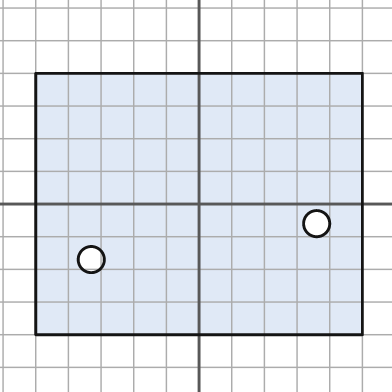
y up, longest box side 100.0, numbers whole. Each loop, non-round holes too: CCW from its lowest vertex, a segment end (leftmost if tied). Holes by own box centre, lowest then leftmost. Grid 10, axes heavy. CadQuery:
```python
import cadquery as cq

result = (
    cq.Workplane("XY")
    .moveTo(-50.0, -40.0)
    .lineTo(50.0, -40.0)
    .lineTo(50.0, 40.0)
    .lineTo(-50.0, 40.0)
    .close()
    .moveTo(-33.0, -17.0)
    .circle(4.0)
    .moveTo(36.0, -6.0)
    .circle(4.0)
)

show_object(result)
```